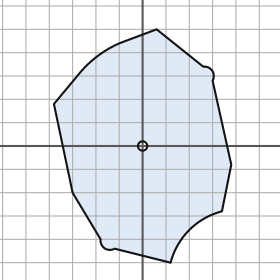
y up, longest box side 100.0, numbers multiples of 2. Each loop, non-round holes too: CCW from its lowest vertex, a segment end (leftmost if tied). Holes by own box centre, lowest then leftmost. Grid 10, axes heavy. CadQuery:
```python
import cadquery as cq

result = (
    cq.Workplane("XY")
    .moveTo(12.0, -50.0)
    .threePointArc((20.0, -36.0), (34.0, -28.0))
    .lineTo(38.0, -8.0)
    .lineTo(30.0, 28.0)
    .threePointArc((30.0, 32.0), (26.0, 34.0))
    .lineTo(6.0, 50.0)
    .lineTo(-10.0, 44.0)
    .threePointArc((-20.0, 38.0), (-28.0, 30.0))
    .lineTo(-38.0, 18.0)
    .lineTo(-30.0, -20.0)
    .lineTo(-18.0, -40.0)
    .threePointArc((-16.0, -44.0), (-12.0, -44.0))
    .close()
    .moveTo(0.0, 0.0)
    .circle(2.0)
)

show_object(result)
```